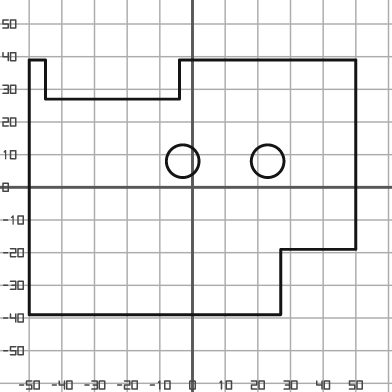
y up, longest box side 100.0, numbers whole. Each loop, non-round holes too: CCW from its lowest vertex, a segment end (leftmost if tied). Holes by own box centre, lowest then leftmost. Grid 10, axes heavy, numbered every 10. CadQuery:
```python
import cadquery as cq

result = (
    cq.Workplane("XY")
    .moveTo(-50.0, -39.0)
    .lineTo(27.0, -39.0)
    .lineTo(27.0, -19.0)
    .lineTo(50.0, -19.0)
    .lineTo(50.0, 39.0)
    .lineTo(-4.0, 39.0)
    .lineTo(-4.0, 27.0)
    .lineTo(-45.0, 27.0)
    .lineTo(-45.0, 39.0)
    .lineTo(-50.0, 39.0)
    .close()
    .moveTo(-3.0, 8.0)
    .circle(5.0)
    .moveTo(23.0, 8.0)
    .circle(5.0)
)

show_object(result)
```